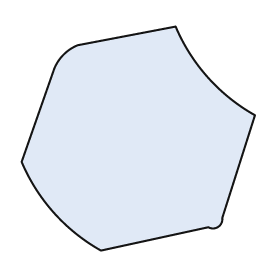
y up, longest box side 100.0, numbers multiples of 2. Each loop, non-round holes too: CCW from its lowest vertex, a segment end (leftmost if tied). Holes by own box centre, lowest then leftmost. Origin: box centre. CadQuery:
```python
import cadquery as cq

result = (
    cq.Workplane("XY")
    .moveTo(-16.0, -48.0)
    .lineTo(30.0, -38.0)
    .threePointArc((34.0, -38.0), (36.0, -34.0))
    .lineTo(50.0, 10.0)
    .threePointArc((30.0, 26.0), (16.0, 48.0))
    .lineTo(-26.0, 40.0)
    .threePointArc((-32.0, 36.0), (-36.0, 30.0))
    .lineTo(-50.0, -10.0)
    .threePointArc((-36.0, -32.0), (-16.0, -48.0))
    .close()
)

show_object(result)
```